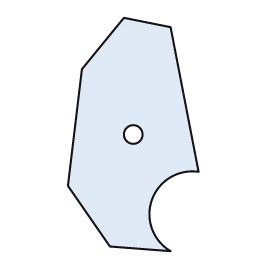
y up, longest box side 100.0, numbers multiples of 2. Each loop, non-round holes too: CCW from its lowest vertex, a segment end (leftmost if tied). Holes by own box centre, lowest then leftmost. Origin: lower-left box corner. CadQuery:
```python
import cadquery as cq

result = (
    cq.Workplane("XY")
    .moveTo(44.0, 0.0)
    .threePointArc((36.0, 22.0), (56.0, 34.0))
    .lineTo(44.0, 96.0)
    .lineTo(24.0, 100.0)
    .lineTo(6.0, 78.0)
    .lineTo(0.0, 28.0)
    .lineTo(18.0, 2.0)
    .close()
    .moveTo(28.0, 50.0)
    .circle(4.0)
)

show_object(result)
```